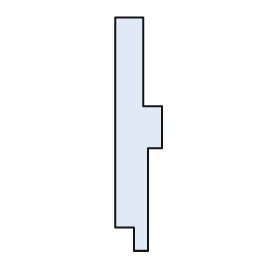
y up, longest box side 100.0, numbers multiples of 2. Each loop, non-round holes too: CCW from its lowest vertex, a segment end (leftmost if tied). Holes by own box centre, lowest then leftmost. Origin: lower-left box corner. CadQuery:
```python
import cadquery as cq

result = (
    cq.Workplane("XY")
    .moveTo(8.0, 0.0)
    .lineTo(14.0, 0.0)
    .lineTo(14.0, 44.0)
    .lineTo(20.0, 44.0)
    .lineTo(20.0, 62.0)
    .lineTo(12.0, 62.0)
    .lineTo(12.0, 100.0)
    .lineTo(0.0, 100.0)
    .lineTo(0.0, 10.0)
    .lineTo(8.0, 10.0)
    .close()
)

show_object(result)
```